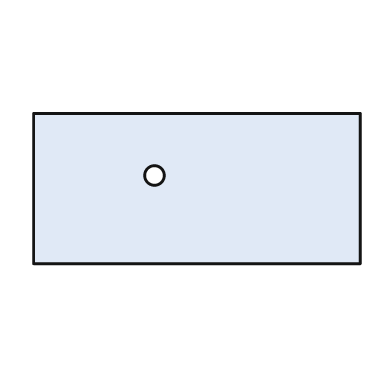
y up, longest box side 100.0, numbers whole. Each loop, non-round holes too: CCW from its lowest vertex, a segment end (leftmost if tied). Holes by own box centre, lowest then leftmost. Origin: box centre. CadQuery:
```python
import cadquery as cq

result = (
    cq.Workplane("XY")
    .moveTo(-50.0, -23.0)
    .lineTo(50.0, -23.0)
    .lineTo(50.0, 23.0)
    .lineTo(-50.0, 23.0)
    .close()
    .moveTo(-13.0, 4.0)
    .circle(3.0)
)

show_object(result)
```